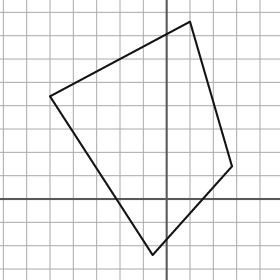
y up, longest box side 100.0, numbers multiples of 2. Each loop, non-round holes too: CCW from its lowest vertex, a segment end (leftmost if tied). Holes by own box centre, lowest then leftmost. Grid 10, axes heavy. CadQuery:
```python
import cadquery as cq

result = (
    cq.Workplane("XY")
    .moveTo(-6.0, -24.0)
    .lineTo(28.0, 14.0)
    .lineTo(10.0, 76.0)
    .lineTo(-50.0, 44.0)
    .close()
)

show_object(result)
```